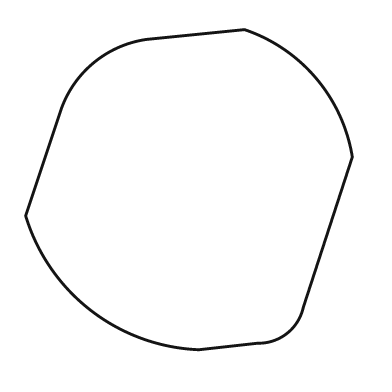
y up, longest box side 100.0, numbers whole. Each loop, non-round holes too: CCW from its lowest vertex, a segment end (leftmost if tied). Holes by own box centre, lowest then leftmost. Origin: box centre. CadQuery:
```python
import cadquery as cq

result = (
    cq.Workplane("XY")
    .moveTo(3.0, -49.0)
    .lineTo(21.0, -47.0)
    .threePointArc((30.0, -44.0), (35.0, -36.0))
    .lineTo(50.0, 10.0)
    .threePointArc((39.0, 34.0), (17.0, 49.0))
    .lineTo(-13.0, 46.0)
    .threePointArc((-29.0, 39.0), (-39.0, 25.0))
    .lineTo(-50.0, -8.0)
    .threePointArc((-30.0, -37.0), (3.0, -49.0))
    .close()
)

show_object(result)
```